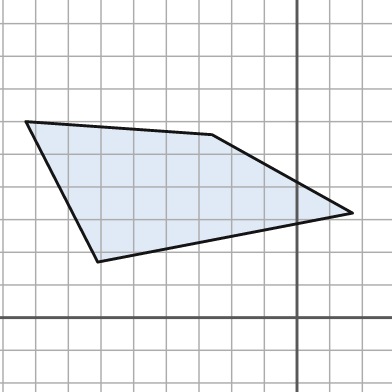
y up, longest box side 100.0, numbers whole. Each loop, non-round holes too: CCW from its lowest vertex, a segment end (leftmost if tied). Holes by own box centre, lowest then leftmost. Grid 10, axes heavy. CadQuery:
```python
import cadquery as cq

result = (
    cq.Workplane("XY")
    .moveTo(-61.0, 17.0)
    .lineTo(17.0, 32.0)
    .lineTo(-26.0, 56.0)
    .lineTo(-83.0, 60.0)
    .close()
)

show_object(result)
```